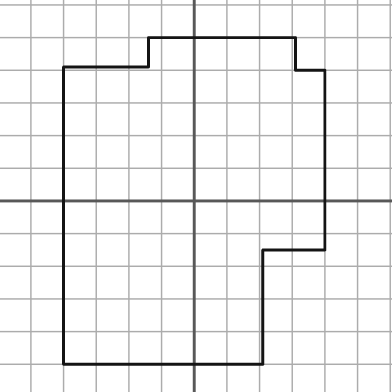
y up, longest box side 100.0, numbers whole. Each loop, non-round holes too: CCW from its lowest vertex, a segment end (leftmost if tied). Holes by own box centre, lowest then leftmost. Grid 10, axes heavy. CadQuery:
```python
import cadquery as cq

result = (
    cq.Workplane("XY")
    .moveTo(-40.0, -50.0)
    .lineTo(21.0, -50.0)
    .lineTo(21.0, -15.0)
    .lineTo(40.0, -15.0)
    .lineTo(40.0, 40.0)
    .lineTo(31.0, 40.0)
    .lineTo(31.0, 50.0)
    .lineTo(-14.0, 50.0)
    .lineTo(-14.0, 41.0)
    .lineTo(-40.0, 41.0)
    .close()
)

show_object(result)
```